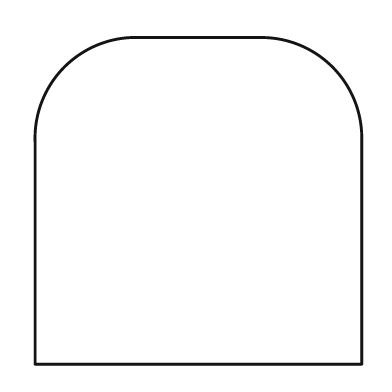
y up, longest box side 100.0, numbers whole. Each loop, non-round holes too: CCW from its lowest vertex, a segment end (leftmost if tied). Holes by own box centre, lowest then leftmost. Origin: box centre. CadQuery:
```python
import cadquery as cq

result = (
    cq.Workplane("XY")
    .moveTo(-50.0, -50.0)
    .lineTo(50.0, -50.0)
    .lineTo(50.0, 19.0)
    .threePointArc((41.0, 41.0), (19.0, 50.0))
    .lineTo(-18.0, 50.0)
    .threePointArc((-41.0, 41.0), (-50.0, 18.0))
    .close()
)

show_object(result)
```